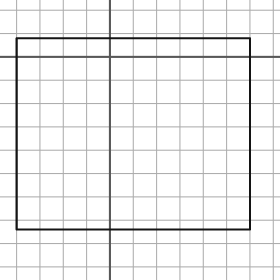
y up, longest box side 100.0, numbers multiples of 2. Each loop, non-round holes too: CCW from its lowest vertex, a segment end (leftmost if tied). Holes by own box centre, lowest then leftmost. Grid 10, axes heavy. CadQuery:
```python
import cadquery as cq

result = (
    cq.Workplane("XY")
    .moveTo(-40.0, -74.0)
    .lineTo(60.0, -74.0)
    .lineTo(60.0, 8.0)
    .lineTo(-40.0, 8.0)
    .close()
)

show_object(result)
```